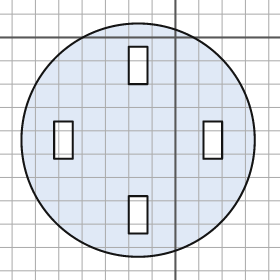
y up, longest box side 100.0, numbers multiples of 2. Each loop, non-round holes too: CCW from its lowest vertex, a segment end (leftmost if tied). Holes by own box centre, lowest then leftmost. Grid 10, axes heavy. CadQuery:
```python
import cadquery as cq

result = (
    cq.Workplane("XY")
    .moveTo(-16.0, -44.0)
    .circle(50.0)
    .moveTo(-20.0, -84.0)
    .lineTo(-12.0, -84.0)
    .lineTo(-12.0, -68.0)
    .lineTo(-20.0, -68.0)
    .close()
    .moveTo(-52.0, -52.0)
    .lineTo(-44.0, -52.0)
    .lineTo(-44.0, -36.0)
    .lineTo(-52.0, -36.0)
    .close()
    .moveTo(12.0, -52.0)
    .lineTo(20.0, -52.0)
    .lineTo(20.0, -36.0)
    .lineTo(12.0, -36.0)
    .close()
    .moveTo(-20.0, -20.0)
    .lineTo(-12.0, -20.0)
    .lineTo(-12.0, -4.0)
    .lineTo(-20.0, -4.0)
    .close()
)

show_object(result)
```